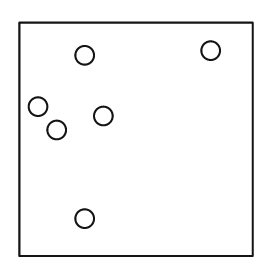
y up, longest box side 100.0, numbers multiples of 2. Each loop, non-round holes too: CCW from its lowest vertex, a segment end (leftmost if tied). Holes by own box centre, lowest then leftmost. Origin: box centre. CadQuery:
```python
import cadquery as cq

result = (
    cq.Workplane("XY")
    .moveTo(-50.0, -50.0)
    .lineTo(50.0, -50.0)
    .lineTo(50.0, 50.0)
    .lineTo(-50.0, 50.0)
    .close()
    .moveTo(-22.0, -34.0)
    .circle(4.0)
    .moveTo(-34.0, 4.0)
    .circle(4.0)
    .moveTo(-14.0, 10.0)
    .circle(4.0)
    .moveTo(-42.0, 14.0)
    .circle(4.0)
    .moveTo(-22.0, 36.0)
    .circle(4.0)
    .moveTo(32.0, 38.0)
    .circle(4.0)
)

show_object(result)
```